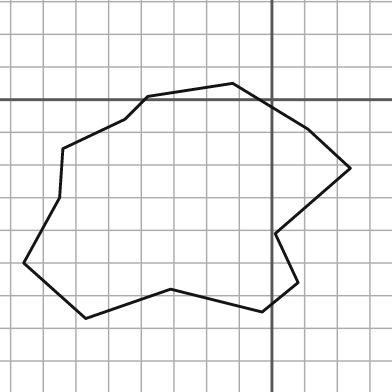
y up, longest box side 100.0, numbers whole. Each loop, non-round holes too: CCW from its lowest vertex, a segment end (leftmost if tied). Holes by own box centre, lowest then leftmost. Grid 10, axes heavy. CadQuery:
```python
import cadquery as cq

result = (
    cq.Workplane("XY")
    .moveTo(-57.0, -67.0)
    .lineTo(-31.0, -58.0)
    .lineTo(-3.0, -65.0)
    .lineTo(8.0, -56.0)
    .lineTo(1.0, -41.0)
    .lineTo(24.0, -21.0)
    .lineTo(11.0, -9.0)
    .lineTo(-12.0, 5.0)
    .lineTo(-38.0, 1.0)
    .lineTo(-45.0, -6.0)
    .lineTo(-64.0, -15.0)
    .lineTo(-65.0, -30.0)
    .lineTo(-76.0, -50.0)
    .close()
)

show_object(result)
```